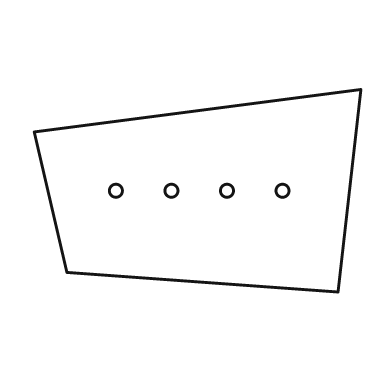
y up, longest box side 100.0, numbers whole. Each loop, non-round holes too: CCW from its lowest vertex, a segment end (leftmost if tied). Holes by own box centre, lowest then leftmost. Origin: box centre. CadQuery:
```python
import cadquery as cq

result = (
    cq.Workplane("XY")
    .moveTo(43.0, -31.0)
    .lineTo(50.0, 31.0)
    .lineTo(-50.0, 18.0)
    .lineTo(-40.0, -25.0)
    .close()
    .moveTo(-25.0, 0.0)
    .circle(2.0)
    .moveTo(-8.0, 0.0)
    .circle(2.0)
    .moveTo(9.0, 0.0)
    .circle(2.0)
    .moveTo(26.0, 0.0)
    .circle(2.0)
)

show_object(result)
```